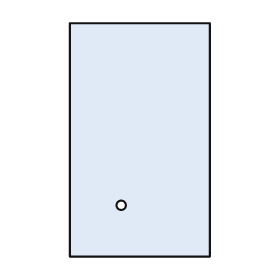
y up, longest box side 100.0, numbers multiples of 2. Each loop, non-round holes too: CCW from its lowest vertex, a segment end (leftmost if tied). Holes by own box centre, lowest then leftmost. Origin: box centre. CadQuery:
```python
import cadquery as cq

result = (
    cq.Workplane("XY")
    .moveTo(-30.0, -50.0)
    .lineTo(30.0, -50.0)
    .lineTo(30.0, 50.0)
    .lineTo(-30.0, 50.0)
    .close()
    .moveTo(-8.0, -28.0)
    .circle(2.0)
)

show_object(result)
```